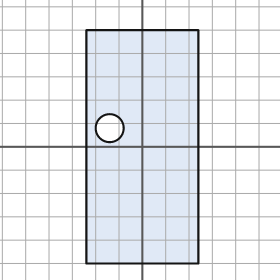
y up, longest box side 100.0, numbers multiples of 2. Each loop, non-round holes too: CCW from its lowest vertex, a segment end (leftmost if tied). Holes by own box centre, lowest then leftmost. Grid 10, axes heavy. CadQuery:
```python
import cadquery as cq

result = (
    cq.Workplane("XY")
    .moveTo(-24.0, -50.0)
    .lineTo(24.0, -50.0)
    .lineTo(24.0, 50.0)
    .lineTo(-24.0, 50.0)
    .close()
    .moveTo(-14.0, 8.0)
    .circle(6.0)
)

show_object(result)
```